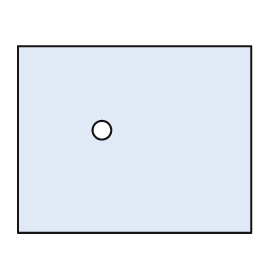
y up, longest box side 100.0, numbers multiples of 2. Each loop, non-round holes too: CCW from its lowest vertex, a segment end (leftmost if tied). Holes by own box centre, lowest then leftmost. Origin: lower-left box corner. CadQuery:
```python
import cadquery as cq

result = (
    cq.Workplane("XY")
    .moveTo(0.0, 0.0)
    .lineTo(100.0, 0.0)
    .lineTo(100.0, 80.0)
    .lineTo(0.0, 80.0)
    .close()
    .moveTo(36.0, 44.0)
    .circle(4.0)
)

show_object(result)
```